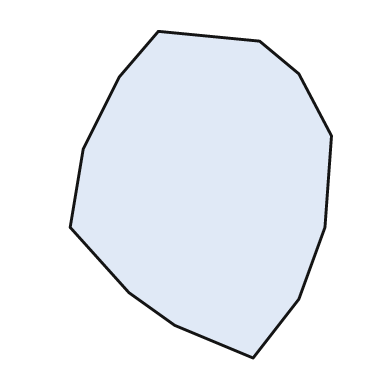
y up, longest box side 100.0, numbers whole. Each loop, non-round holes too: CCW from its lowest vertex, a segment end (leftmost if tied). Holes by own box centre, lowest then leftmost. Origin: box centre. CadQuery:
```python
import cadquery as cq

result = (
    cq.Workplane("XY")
    .moveTo(16.0, -50.0)
    .lineTo(30.0, -32.0)
    .lineTo(38.0, -10.0)
    .lineTo(40.0, 18.0)
    .lineTo(30.0, 37.0)
    .lineTo(18.0, 47.0)
    .lineTo(-13.0, 50.0)
    .lineTo(-25.0, 36.0)
    .lineTo(-36.0, 14.0)
    .lineTo(-40.0, -10.0)
    .lineTo(-22.0, -30.0)
    .lineTo(-8.0, -40.0)
    .close()
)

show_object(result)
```